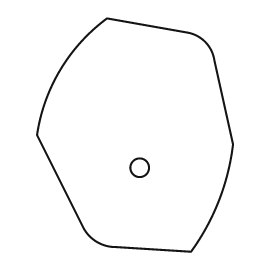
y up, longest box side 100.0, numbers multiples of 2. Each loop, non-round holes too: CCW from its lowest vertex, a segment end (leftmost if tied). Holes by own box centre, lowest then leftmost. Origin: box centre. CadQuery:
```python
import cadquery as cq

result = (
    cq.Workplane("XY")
    .moveTo(24.0, -50.0)
    .threePointArc((36.0, -28.0), (42.0, -4.0))
    .lineTo(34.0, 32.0)
    .threePointArc((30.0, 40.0), (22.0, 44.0))
    .lineTo(-12.0, 50.0)
    .threePointArc((-32.0, 28.0), (-42.0, 0.0))
    .lineTo(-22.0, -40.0)
    .threePointArc((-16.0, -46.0), (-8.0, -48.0))
    .close()
    .moveTo(2.0, -14.0)
    .circle(4.0)
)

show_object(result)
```